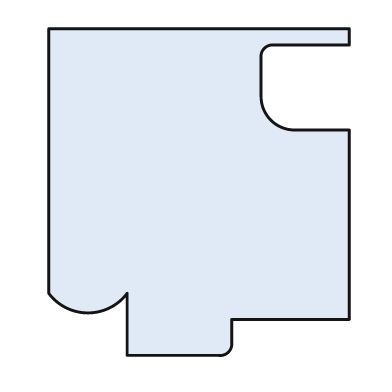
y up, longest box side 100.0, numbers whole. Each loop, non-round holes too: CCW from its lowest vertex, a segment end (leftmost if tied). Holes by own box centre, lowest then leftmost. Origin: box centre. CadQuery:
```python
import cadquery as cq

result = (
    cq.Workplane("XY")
    .moveTo(-22.0, -50.0)
    .lineTo(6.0, -50.0)
    .threePointArc((9.0, -49.0), (10.0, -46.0))
    .lineTo(10.0, -39.0)
    .lineTo(46.0, -39.0)
    .lineTo(46.0, 19.0)
    .lineTo(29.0, 19.0)
    .threePointArc((22.0, 22.0), (19.0, 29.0))
    .lineTo(19.0, 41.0)
    .threePointArc((20.0, 44.0), (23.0, 45.0))
    .lineTo(46.0, 45.0)
    .lineTo(46.0, 50.0)
    .lineTo(-46.0, 50.0)
    .lineTo(-46.0, -31.0)
    .threePointArc((-34.0, -37.0), (-22.0, -31.0))
    .close()
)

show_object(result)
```